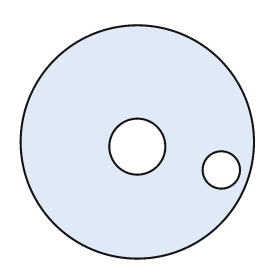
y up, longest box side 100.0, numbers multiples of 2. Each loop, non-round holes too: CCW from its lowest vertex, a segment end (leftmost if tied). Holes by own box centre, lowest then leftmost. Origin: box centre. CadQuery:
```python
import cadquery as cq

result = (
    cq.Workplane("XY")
    .moveTo(0.0, 0.0)
    .circle(50.0)
    .moveTo(36.0, -12.0)
    .circle(8.0)
    .moveTo(0.0, -2.0)
    .circle(12.0)
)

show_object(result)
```